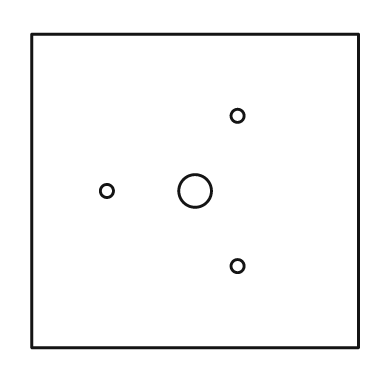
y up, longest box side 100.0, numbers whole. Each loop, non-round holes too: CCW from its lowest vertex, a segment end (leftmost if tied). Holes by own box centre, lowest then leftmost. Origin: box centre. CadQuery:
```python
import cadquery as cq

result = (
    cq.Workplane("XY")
    .moveTo(-50.0, -48.0)
    .lineTo(50.0, -48.0)
    .lineTo(50.0, 48.0)
    .lineTo(-50.0, 48.0)
    .close()
    .moveTo(13.0, -23.0)
    .circle(2.0)
    .moveTo(-27.0, 0.0)
    .circle(2.0)
    .moveTo(0.0, 0.0)
    .circle(5.0)
    .moveTo(13.0, 23.0)
    .circle(2.0)
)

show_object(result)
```